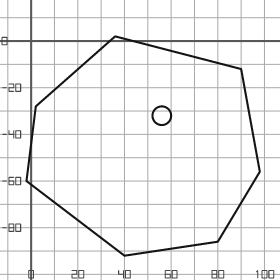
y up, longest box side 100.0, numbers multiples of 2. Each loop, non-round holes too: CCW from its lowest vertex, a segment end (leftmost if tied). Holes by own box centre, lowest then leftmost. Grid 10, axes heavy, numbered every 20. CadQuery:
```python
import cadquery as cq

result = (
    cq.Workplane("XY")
    .moveTo(40.0, -92.0)
    .lineTo(80.0, -86.0)
    .lineTo(98.0, -56.0)
    .lineTo(90.0, -12.0)
    .lineTo(36.0, 2.0)
    .lineTo(2.0, -28.0)
    .lineTo(-2.0, -60.0)
    .close()
    .moveTo(56.0, -32.0)
    .circle(4.0)
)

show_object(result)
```